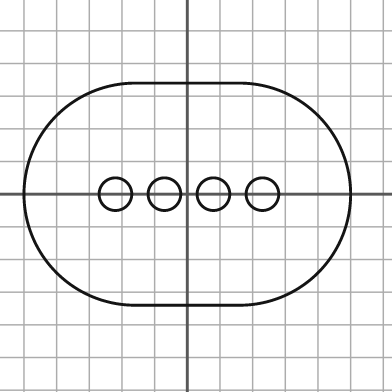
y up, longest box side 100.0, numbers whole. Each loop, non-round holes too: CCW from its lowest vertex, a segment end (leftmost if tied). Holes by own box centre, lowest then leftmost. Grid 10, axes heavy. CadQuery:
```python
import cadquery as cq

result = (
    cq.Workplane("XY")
    .moveTo(-16.0, -34.0)
    .lineTo(16.0, -34.0)
    .threePointArc((50.0, 0.0), (16.0, 34.0))
    .lineTo(-16.0, 34.0)
    .threePointArc((-50.0, 0.0), (-16.0, -34.0))
    .close()
    .moveTo(-22.0, 0.0)
    .circle(5.0)
    .moveTo(-7.0, 0.0)
    .circle(5.0)
    .moveTo(8.0, 0.0)
    .circle(5.0)
    .moveTo(23.0, 0.0)
    .circle(5.0)
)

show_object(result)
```